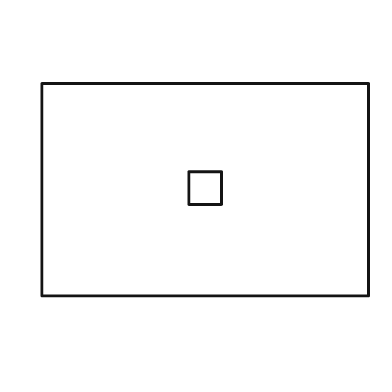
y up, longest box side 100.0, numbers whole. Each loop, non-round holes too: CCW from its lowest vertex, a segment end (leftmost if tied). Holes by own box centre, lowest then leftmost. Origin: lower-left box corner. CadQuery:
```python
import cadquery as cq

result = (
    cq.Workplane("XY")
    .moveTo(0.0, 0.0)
    .lineTo(100.0, 0.0)
    .lineTo(100.0, 65.0)
    .lineTo(0.0, 65.0)
    .close()
    .moveTo(45.0, 28.0)
    .lineTo(55.0, 28.0)
    .lineTo(55.0, 38.0)
    .lineTo(45.0, 38.0)
    .close()
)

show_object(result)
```